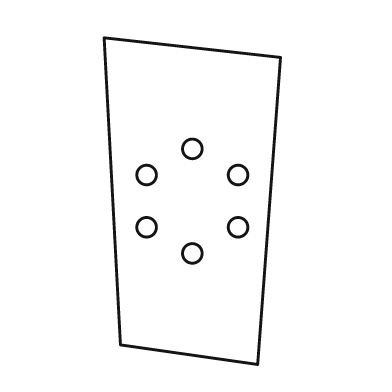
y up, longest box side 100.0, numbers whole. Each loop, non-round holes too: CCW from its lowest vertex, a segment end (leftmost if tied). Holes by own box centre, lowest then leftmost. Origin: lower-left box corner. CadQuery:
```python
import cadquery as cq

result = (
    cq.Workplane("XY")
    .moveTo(47.0, 0.0)
    .lineTo(54.0, 94.0)
    .lineTo(0.0, 100.0)
    .lineTo(5.0, 6.0)
    .close()
    .moveTo(27.0, 34.0)
    .circle(3.0)
    .moveTo(13.0, 42.0)
    .circle(3.0)
    .moveTo(41.0, 42.0)
    .circle(3.0)
    .moveTo(13.0, 58.0)
    .circle(3.0)
    .moveTo(41.0, 58.0)
    .circle(3.0)
    .moveTo(27.0, 66.0)
    .circle(3.0)
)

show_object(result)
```